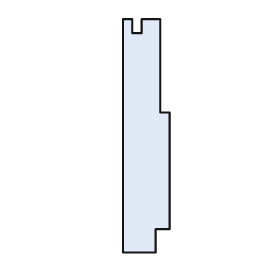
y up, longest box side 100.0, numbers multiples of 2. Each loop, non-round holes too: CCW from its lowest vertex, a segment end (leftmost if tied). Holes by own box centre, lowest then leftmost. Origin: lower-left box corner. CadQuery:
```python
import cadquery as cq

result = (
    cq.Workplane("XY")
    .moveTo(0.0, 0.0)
    .lineTo(14.0, 0.0)
    .lineTo(14.0, 10.0)
    .lineTo(20.0, 10.0)
    .lineTo(20.0, 60.0)
    .lineTo(16.0, 60.0)
    .lineTo(16.0, 100.0)
    .lineTo(8.0, 100.0)
    .lineTo(8.0, 94.0)
    .lineTo(4.0, 94.0)
    .lineTo(4.0, 100.0)
    .lineTo(0.0, 100.0)
    .close()
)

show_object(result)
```